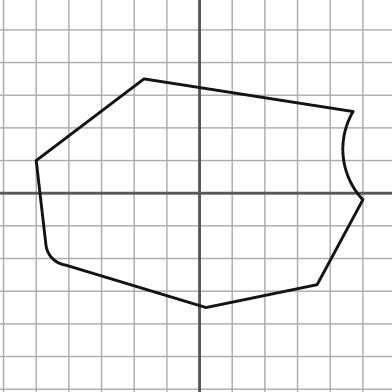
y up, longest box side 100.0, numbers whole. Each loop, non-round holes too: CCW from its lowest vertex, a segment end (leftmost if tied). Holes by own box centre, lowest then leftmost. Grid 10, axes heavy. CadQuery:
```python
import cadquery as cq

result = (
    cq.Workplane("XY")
    .moveTo(2.0, -35.0)
    .lineTo(36.0, -28.0)
    .lineTo(50.0, -2.0)
    .threePointArc((44.0, 11.0), (47.0, 25.0))
    .lineTo(-17.0, 35.0)
    .lineTo(-50.0, 10.0)
    .lineTo(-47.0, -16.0)
    .threePointArc((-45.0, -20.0), (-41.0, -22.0))
    .close()
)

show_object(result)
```